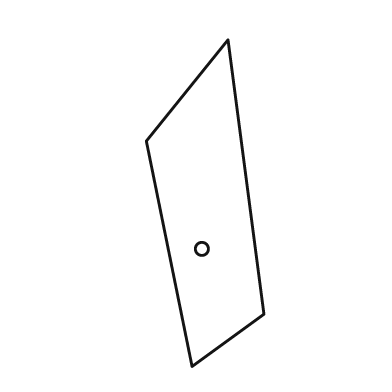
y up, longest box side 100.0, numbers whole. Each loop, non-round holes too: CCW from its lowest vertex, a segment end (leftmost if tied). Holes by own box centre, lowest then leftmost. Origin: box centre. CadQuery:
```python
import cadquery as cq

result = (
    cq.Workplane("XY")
    .moveTo(-4.0, -50.0)
    .lineTo(18.0, -34.0)
    .lineTo(7.0, 50.0)
    .lineTo(-18.0, 19.0)
    .close()
    .moveTo(-1.0, -14.0)
    .circle(2.0)
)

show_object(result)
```